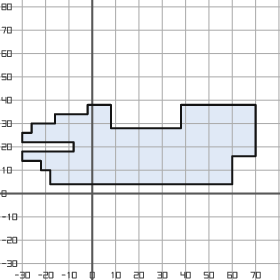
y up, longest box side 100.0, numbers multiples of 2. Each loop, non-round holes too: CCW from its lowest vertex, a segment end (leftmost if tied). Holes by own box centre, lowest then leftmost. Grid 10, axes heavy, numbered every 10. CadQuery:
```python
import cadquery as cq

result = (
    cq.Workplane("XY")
    .moveTo(-18.0, 4.0)
    .lineTo(60.0, 4.0)
    .lineTo(60.0, 16.0)
    .lineTo(70.0, 16.0)
    .lineTo(70.0, 38.0)
    .lineTo(38.0, 38.0)
    .lineTo(38.0, 28.0)
    .lineTo(8.0, 28.0)
    .lineTo(8.0, 38.0)
    .lineTo(-2.0, 38.0)
    .lineTo(-2.0, 34.0)
    .lineTo(-16.0, 34.0)
    .lineTo(-16.0, 30.0)
    .lineTo(-26.0, 30.0)
    .lineTo(-26.0, 26.0)
    .lineTo(-30.0, 26.0)
    .lineTo(-30.0, 22.0)
    .lineTo(-8.0, 22.0)
    .lineTo(-8.0, 18.0)
    .lineTo(-30.0, 18.0)
    .lineTo(-30.0, 14.0)
    .lineTo(-22.0, 14.0)
    .lineTo(-22.0, 10.0)
    .lineTo(-18.0, 10.0)
    .close()
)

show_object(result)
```